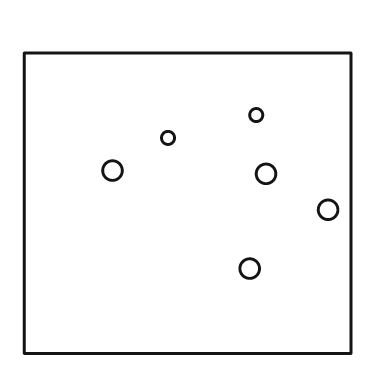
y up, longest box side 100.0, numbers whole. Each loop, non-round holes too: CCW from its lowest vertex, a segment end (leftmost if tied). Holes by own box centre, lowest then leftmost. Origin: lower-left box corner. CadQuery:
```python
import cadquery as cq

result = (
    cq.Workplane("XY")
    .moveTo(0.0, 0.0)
    .lineTo(100.0, 0.0)
    .lineTo(100.0, 92.0)
    .lineTo(0.0, 92.0)
    .close()
    .moveTo(69.0, 26.0)
    .circle(3.0)
    .moveTo(93.0, 44.0)
    .circle(3.0)
    .moveTo(74.0, 55.0)
    .circle(3.0)
    .moveTo(27.0, 56.0)
    .circle(3.0)
    .moveTo(44.0, 66.0)
    .circle(2.0)
    .moveTo(71.0, 73.0)
    .circle(2.0)
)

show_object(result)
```